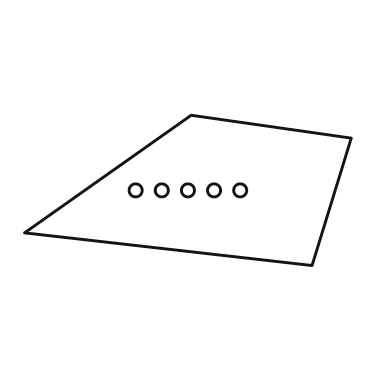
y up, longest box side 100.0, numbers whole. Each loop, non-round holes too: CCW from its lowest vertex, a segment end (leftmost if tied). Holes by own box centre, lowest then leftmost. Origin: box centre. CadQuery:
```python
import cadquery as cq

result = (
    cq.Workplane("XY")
    .moveTo(38.0, -23.0)
    .lineTo(50.0, 16.0)
    .lineTo(1.0, 23.0)
    .lineTo(-50.0, -13.0)
    .close()
    .moveTo(-16.0, 0.0)
    .circle(2.0)
    .moveTo(-8.0, 0.0)
    .circle(2.0)
    .moveTo(0.0, 0.0)
    .circle(2.0)
    .moveTo(8.0, 0.0)
    .circle(2.0)
    .moveTo(16.0, 0.0)
    .circle(2.0)
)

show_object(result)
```